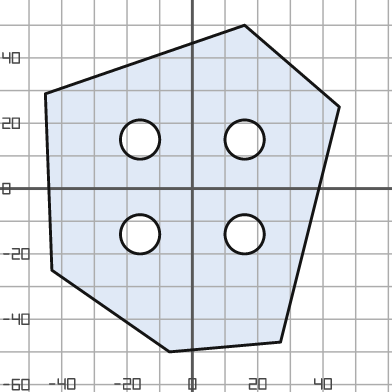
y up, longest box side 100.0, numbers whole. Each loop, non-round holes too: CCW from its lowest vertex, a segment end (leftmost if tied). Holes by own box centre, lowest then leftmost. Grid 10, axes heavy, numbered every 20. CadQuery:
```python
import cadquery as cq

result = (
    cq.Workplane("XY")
    .moveTo(-7.0, -50.0)
    .lineTo(27.0, -47.0)
    .lineTo(45.0, 25.0)
    .lineTo(16.0, 50.0)
    .lineTo(-45.0, 29.0)
    .lineTo(-43.0, -25.0)
    .close()
    .moveTo(-16.0, -14.0)
    .circle(6.0)
    .moveTo(16.0, -14.0)
    .circle(6.0)
    .moveTo(-16.0, 15.0)
    .circle(6.0)
    .moveTo(16.0, 15.0)
    .circle(6.0)
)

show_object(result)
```